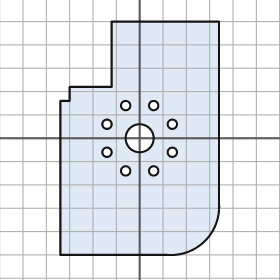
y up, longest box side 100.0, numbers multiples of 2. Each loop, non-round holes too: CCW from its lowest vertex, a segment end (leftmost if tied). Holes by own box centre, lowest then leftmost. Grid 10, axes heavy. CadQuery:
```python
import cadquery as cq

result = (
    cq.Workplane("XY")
    .moveTo(-34.0, -50.0)
    .lineTo(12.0, -50.0)
    .threePointArc((28.0, -44.0), (34.0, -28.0))
    .lineTo(34.0, 50.0)
    .lineTo(-12.0, 50.0)
    .lineTo(-12.0, 22.0)
    .lineTo(-30.0, 22.0)
    .lineTo(-30.0, 16.0)
    .lineTo(-34.0, 16.0)
    .close()
    .moveTo(-6.0, -14.0)
    .circle(2.0)
    .moveTo(6.0, -14.0)
    .circle(2.0)
    .moveTo(-14.0, -6.0)
    .circle(2.0)
    .moveTo(14.0, -6.0)
    .circle(2.0)
    .moveTo(0.0, 0.0)
    .circle(6.0)
    .moveTo(-14.0, 6.0)
    .circle(2.0)
    .moveTo(14.0, 6.0)
    .circle(2.0)
    .moveTo(-6.0, 14.0)
    .circle(2.0)
    .moveTo(6.0, 14.0)
    .circle(2.0)
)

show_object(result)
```